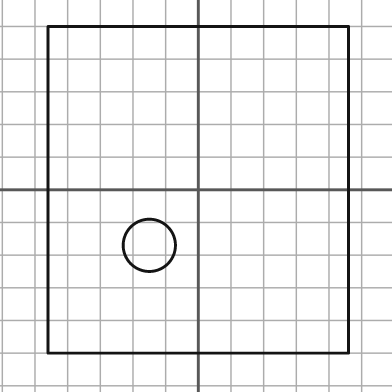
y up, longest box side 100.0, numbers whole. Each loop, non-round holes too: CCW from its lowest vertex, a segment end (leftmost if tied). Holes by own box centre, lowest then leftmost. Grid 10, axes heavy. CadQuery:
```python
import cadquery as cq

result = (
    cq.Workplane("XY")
    .moveTo(-46.0, -50.0)
    .lineTo(46.0, -50.0)
    .lineTo(46.0, 50.0)
    .lineTo(-46.0, 50.0)
    .close()
    .moveTo(-15.0, -17.0)
    .circle(8.0)
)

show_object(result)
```